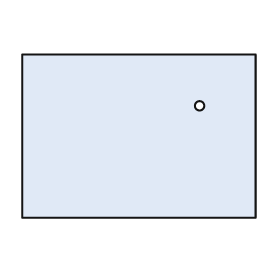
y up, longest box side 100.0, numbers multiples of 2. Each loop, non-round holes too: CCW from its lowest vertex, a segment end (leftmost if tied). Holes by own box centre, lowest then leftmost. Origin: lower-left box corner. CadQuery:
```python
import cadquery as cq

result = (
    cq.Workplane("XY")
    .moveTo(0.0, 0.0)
    .lineTo(100.0, 0.0)
    .lineTo(100.0, 70.0)
    .lineTo(0.0, 70.0)
    .close()
    .moveTo(76.0, 48.0)
    .circle(2.0)
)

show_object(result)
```